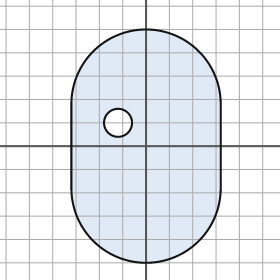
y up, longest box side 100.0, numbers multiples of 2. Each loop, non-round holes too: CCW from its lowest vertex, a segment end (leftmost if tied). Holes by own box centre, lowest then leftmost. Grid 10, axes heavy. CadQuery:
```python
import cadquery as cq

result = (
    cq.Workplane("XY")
    .moveTo(-32.0, -18.0)
    .threePointArc((0.0, -50.0), (32.0, -18.0))
    .lineTo(32.0, 18.0)
    .threePointArc((0.0, 50.0), (-32.0, 18.0))
    .close()
    .moveTo(-12.0, 10.0)
    .circle(6.0)
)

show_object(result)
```